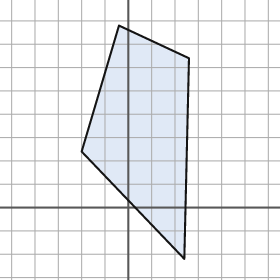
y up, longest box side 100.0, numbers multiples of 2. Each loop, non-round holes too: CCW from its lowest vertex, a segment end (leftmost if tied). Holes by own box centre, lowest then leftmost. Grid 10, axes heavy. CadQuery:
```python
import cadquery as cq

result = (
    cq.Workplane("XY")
    .moveTo(24.0, -22.0)
    .lineTo(26.0, 64.0)
    .lineTo(-4.0, 78.0)
    .lineTo(-20.0, 24.0)
    .close()
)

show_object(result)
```